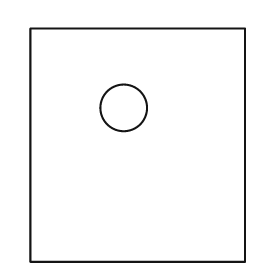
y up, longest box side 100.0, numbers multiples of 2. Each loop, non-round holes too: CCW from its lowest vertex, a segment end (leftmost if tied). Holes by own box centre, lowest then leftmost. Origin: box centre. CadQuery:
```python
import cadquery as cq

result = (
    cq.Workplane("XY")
    .moveTo(-46.0, -50.0)
    .lineTo(46.0, -50.0)
    .lineTo(46.0, 50.0)
    .lineTo(-46.0, 50.0)
    .close()
    .moveTo(-6.0, 16.0)
    .circle(10.0)
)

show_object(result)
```